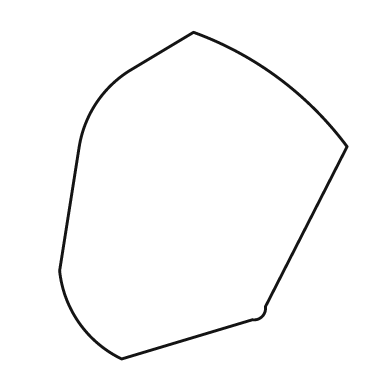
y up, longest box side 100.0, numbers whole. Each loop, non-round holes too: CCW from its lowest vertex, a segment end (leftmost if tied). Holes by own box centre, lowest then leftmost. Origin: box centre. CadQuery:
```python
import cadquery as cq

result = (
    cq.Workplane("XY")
    .moveTo(-25.0, -50.0)
    .lineTo(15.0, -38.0)
    .threePointArc((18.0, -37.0), (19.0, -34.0))
    .lineTo(44.0, 15.0)
    .threePointArc((23.0, 36.0), (-3.0, 50.0))
    .lineTo(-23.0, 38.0)
    .threePointArc((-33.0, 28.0), (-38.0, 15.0))
    .lineTo(-44.0, -23.0)
    .threePointArc((-38.0, -39.0), (-25.0, -50.0))
    .close()
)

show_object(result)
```